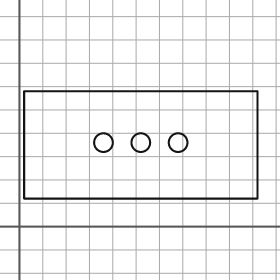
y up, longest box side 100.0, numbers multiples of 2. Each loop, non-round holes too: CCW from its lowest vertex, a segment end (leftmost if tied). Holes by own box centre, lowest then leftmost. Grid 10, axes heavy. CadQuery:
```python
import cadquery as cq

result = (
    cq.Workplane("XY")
    .moveTo(2.0, 12.0)
    .lineTo(102.0, 12.0)
    .lineTo(102.0, 58.0)
    .lineTo(2.0, 58.0)
    .close()
    .moveTo(36.0, 36.0)
    .circle(4.0)
    .moveTo(52.0, 36.0)
    .circle(4.0)
    .moveTo(68.0, 36.0)
    .circle(4.0)
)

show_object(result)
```